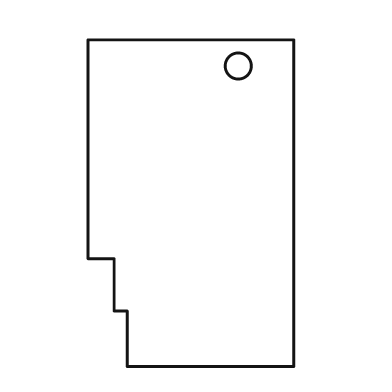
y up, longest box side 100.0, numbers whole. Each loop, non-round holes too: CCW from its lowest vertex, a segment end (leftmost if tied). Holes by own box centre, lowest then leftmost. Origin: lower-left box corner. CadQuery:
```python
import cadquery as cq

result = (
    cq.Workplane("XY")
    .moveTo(12.0, 0.0)
    .lineTo(63.0, 0.0)
    .lineTo(63.0, 100.0)
    .lineTo(0.0, 100.0)
    .lineTo(0.0, 33.0)
    .lineTo(8.0, 33.0)
    .lineTo(8.0, 17.0)
    .lineTo(12.0, 17.0)
    .close()
    .moveTo(46.0, 92.0)
    .circle(4.0)
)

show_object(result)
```